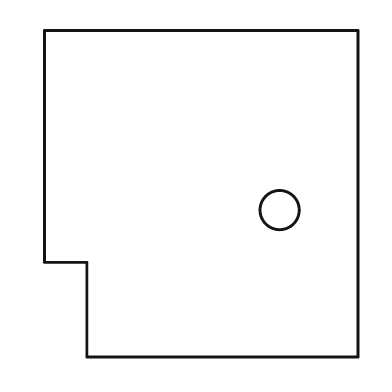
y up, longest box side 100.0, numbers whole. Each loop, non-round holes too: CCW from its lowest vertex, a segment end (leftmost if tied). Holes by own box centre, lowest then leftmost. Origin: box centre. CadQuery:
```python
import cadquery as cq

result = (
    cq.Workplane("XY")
    .moveTo(-35.0, -50.0)
    .lineTo(48.0, -50.0)
    .lineTo(48.0, 50.0)
    .lineTo(-48.0, 50.0)
    .lineTo(-48.0, -21.0)
    .lineTo(-35.0, -21.0)
    .close()
    .moveTo(24.0, -5.0)
    .circle(6.0)
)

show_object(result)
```